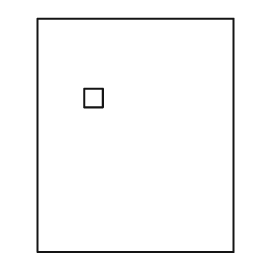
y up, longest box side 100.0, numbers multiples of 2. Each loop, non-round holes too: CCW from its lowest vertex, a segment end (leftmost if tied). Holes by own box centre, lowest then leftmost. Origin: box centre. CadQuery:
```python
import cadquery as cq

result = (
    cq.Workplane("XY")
    .moveTo(-42.0, -50.0)
    .lineTo(42.0, -50.0)
    .lineTo(42.0, 50.0)
    .lineTo(-42.0, 50.0)
    .close()
    .moveTo(-22.0, 12.0)
    .lineTo(-14.0, 12.0)
    .lineTo(-14.0, 20.0)
    .lineTo(-22.0, 20.0)
    .close()
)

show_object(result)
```